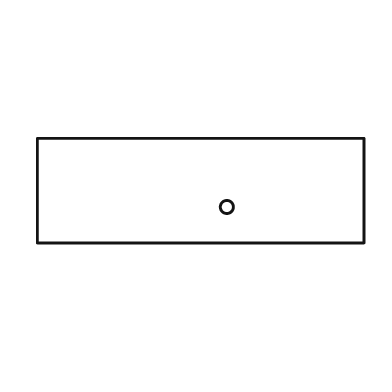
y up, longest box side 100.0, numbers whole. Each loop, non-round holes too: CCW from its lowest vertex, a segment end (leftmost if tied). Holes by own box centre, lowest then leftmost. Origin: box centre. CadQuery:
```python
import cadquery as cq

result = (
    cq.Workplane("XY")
    .moveTo(-50.0, -16.0)
    .lineTo(50.0, -16.0)
    .lineTo(50.0, 16.0)
    .lineTo(-50.0, 16.0)
    .close()
    .moveTo(8.0, -5.0)
    .circle(2.0)
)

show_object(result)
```